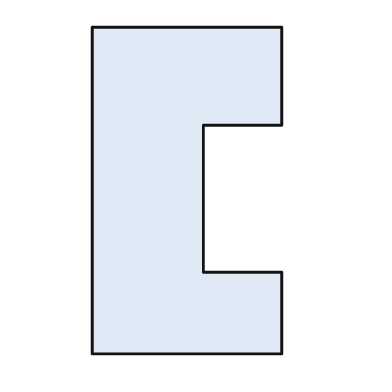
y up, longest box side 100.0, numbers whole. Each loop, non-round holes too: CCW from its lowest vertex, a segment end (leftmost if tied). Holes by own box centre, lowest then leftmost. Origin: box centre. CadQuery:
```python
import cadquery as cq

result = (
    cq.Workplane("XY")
    .moveTo(-29.0, -50.0)
    .lineTo(29.0, -50.0)
    .lineTo(29.0, -25.0)
    .lineTo(5.0, -25.0)
    .lineTo(5.0, 20.0)
    .lineTo(29.0, 20.0)
    .lineTo(29.0, 50.0)
    .lineTo(-29.0, 50.0)
    .close()
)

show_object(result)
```